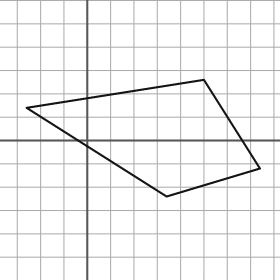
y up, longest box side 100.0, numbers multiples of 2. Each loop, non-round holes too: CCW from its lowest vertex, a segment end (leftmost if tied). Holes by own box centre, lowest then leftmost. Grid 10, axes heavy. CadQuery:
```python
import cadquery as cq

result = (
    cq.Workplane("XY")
    .moveTo(34.0, -24.0)
    .lineTo(74.0, -12.0)
    .lineTo(50.0, 26.0)
    .lineTo(-26.0, 14.0)
    .close()
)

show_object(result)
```